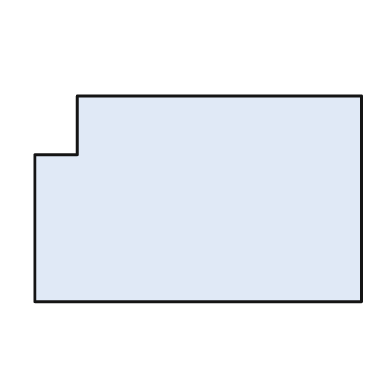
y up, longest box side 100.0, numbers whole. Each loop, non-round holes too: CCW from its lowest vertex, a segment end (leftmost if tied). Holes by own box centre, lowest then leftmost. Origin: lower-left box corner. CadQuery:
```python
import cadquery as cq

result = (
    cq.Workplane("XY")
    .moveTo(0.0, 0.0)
    .lineTo(100.0, 0.0)
    .lineTo(100.0, 63.0)
    .lineTo(13.0, 63.0)
    .lineTo(13.0, 45.0)
    .lineTo(0.0, 45.0)
    .close()
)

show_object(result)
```